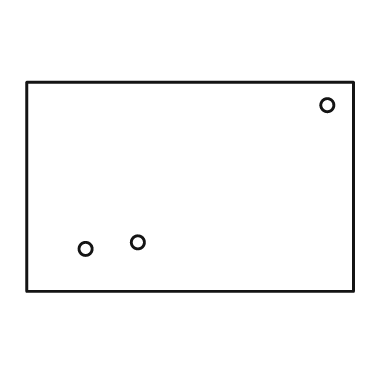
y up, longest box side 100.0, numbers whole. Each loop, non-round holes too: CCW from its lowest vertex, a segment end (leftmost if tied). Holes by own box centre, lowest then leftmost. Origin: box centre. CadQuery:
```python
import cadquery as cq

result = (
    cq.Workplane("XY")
    .moveTo(-50.0, -32.0)
    .lineTo(50.0, -32.0)
    .lineTo(50.0, 32.0)
    .lineTo(-50.0, 32.0)
    .close()
    .moveTo(-32.0, -19.0)
    .circle(2.0)
    .moveTo(-16.0, -17.0)
    .circle(2.0)
    .moveTo(42.0, 25.0)
    .circle(2.0)
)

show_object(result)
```